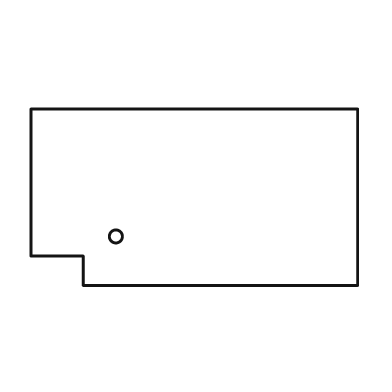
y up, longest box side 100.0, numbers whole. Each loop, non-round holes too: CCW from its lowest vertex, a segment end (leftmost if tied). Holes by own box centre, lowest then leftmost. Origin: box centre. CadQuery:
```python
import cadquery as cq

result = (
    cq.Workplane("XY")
    .moveTo(-34.0, -27.0)
    .lineTo(50.0, -27.0)
    .lineTo(50.0, 27.0)
    .lineTo(-50.0, 27.0)
    .lineTo(-50.0, -18.0)
    .lineTo(-34.0, -18.0)
    .close()
    .moveTo(-24.0, -12.0)
    .circle(2.0)
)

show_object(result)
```